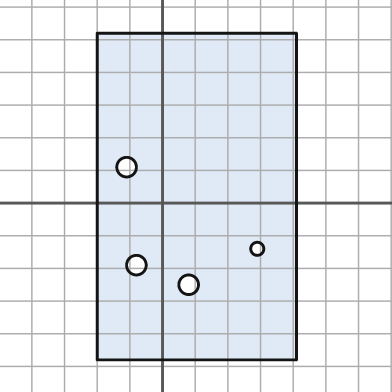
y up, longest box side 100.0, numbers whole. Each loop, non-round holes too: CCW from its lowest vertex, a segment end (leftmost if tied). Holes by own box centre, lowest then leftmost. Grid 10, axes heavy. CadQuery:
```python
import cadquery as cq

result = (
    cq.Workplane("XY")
    .moveTo(-20.0, -48.0)
    .lineTo(41.0, -48.0)
    .lineTo(41.0, 52.0)
    .lineTo(-20.0, 52.0)
    .close()
    .moveTo(8.0, -25.0)
    .circle(3.0)
    .moveTo(-8.0, -19.0)
    .circle(3.0)
    .moveTo(29.0, -14.0)
    .circle(2.0)
    .moveTo(-11.0, 11.0)
    .circle(3.0)
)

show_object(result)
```